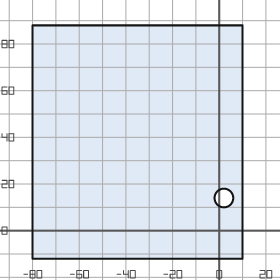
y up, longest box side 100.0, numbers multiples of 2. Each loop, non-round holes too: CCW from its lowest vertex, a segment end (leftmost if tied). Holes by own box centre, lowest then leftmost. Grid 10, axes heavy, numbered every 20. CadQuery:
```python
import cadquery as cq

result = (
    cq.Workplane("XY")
    .moveTo(-80.0, -12.0)
    .lineTo(10.0, -12.0)
    .lineTo(10.0, 88.0)
    .lineTo(-80.0, 88.0)
    .close()
    .moveTo(2.0, 14.0)
    .circle(4.0)
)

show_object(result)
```